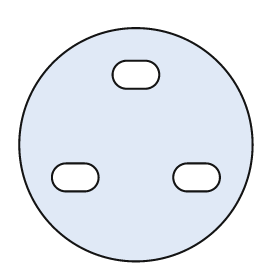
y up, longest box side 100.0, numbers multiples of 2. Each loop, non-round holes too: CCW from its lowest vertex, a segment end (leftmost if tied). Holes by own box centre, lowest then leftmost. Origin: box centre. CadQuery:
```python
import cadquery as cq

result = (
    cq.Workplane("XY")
    .moveTo(0.0, 0.0)
    .circle(50.0)
    .moveTo(-30.0, -20.0)
    .lineTo(-22.0, -20.0)
    .threePointArc((-16.0, -14.0), (-22.0, -8.0))
    .lineTo(-30.0, -8.0)
    .threePointArc((-36.0, -14.0), (-30.0, -20.0))
    .close()
    .moveTo(22.0, -20.0)
    .lineTo(30.0, -20.0)
    .threePointArc((36.0, -14.0), (30.0, -8.0))
    .lineTo(22.0, -8.0)
    .threePointArc((16.0, -14.0), (22.0, -20.0))
    .close()
    .moveTo(-4.0, 24.0)
    .lineTo(4.0, 24.0)
    .threePointArc((10.0, 30.0), (4.0, 36.0))
    .lineTo(-4.0, 36.0)
    .threePointArc((-10.0, 30.0), (-4.0, 24.0))
    .close()
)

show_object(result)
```